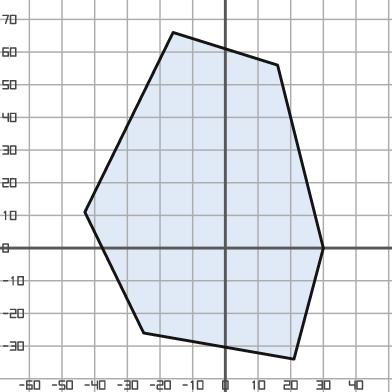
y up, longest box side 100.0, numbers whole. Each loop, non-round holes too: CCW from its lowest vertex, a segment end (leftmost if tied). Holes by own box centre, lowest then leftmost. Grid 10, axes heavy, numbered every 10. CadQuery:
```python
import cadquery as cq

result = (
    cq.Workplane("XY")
    .moveTo(21.0, -34.0)
    .lineTo(30.0, 0.0)
    .lineTo(16.0, 56.0)
    .lineTo(-16.0, 66.0)
    .lineTo(-43.0, 11.0)
    .lineTo(-25.0, -26.0)
    .close()
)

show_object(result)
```